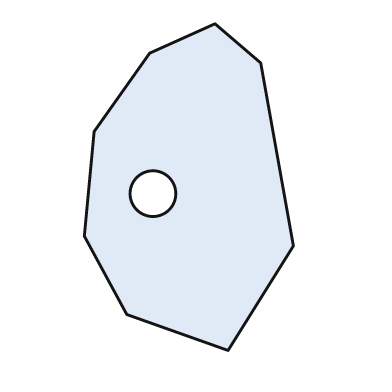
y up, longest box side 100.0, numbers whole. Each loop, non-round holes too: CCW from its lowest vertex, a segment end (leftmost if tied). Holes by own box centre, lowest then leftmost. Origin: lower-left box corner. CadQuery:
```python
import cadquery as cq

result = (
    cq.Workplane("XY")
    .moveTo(44.0, 0.0)
    .lineTo(64.0, 32.0)
    .lineTo(54.0, 88.0)
    .lineTo(40.0, 100.0)
    .lineTo(20.0, 91.0)
    .lineTo(3.0, 67.0)
    .lineTo(0.0, 35.0)
    .lineTo(13.0, 11.0)
    .close()
    .moveTo(21.0, 48.0)
    .circle(7.0)
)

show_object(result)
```